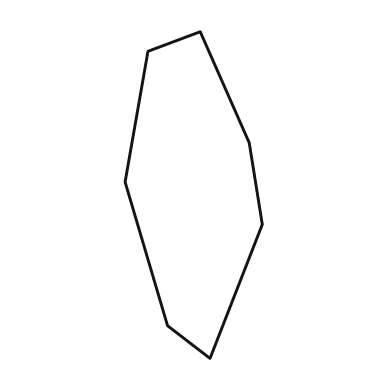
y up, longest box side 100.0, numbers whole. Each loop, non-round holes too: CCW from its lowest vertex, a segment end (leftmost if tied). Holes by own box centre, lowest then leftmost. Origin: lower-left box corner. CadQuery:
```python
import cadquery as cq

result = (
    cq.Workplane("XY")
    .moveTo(26.0, 0.0)
    .lineTo(42.0, 41.0)
    .lineTo(38.0, 66.0)
    .lineTo(23.0, 100.0)
    .lineTo(7.0, 94.0)
    .lineTo(0.0, 54.0)
    .lineTo(13.0, 10.0)
    .close()
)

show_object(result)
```